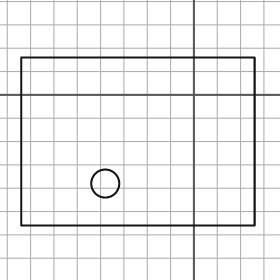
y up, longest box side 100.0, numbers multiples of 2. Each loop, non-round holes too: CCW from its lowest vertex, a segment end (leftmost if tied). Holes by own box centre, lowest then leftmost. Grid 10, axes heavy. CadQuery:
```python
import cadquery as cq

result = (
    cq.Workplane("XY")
    .moveTo(-74.0, -56.0)
    .lineTo(26.0, -56.0)
    .lineTo(26.0, 16.0)
    .lineTo(-74.0, 16.0)
    .close()
    .moveTo(-38.0, -38.0)
    .circle(6.0)
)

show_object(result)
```